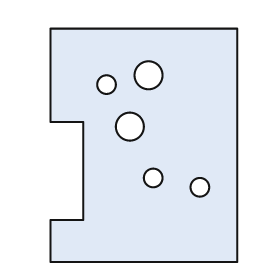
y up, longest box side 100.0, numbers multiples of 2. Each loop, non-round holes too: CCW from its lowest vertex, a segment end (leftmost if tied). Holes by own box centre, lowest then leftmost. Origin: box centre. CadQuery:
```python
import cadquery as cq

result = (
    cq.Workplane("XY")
    .moveTo(-40.0, -50.0)
    .lineTo(40.0, -50.0)
    .lineTo(40.0, 50.0)
    .lineTo(-40.0, 50.0)
    .lineTo(-40.0, 10.0)
    .lineTo(-26.0, 10.0)
    .lineTo(-26.0, -32.0)
    .lineTo(-40.0, -32.0)
    .close()
    .moveTo(24.0, -18.0)
    .circle(4.0)
    .moveTo(4.0, -14.0)
    .circle(4.0)
    .moveTo(-6.0, 8.0)
    .circle(6.0)
    .moveTo(-16.0, 26.0)
    .circle(4.0)
    .moveTo(2.0, 30.0)
    .circle(6.0)
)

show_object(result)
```